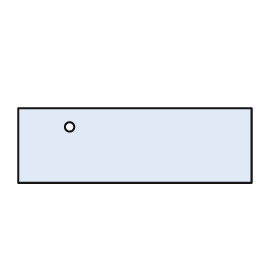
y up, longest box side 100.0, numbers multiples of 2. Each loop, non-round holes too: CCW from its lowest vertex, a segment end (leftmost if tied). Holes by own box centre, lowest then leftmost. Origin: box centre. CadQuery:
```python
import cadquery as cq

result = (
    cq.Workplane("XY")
    .moveTo(-50.0, -16.0)
    .lineTo(50.0, -16.0)
    .lineTo(50.0, 16.0)
    .lineTo(-50.0, 16.0)
    .close()
    .moveTo(-28.0, 8.0)
    .circle(2.0)
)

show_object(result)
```